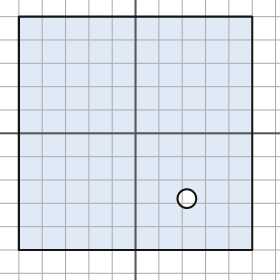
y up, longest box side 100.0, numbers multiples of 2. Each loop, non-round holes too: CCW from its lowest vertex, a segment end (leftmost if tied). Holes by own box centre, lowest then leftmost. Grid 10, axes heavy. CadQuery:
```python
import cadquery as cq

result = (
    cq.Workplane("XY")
    .moveTo(-50.0, -50.0)
    .lineTo(50.0, -50.0)
    .lineTo(50.0, 50.0)
    .lineTo(-50.0, 50.0)
    .close()
    .moveTo(22.0, -28.0)
    .circle(4.0)
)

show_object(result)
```